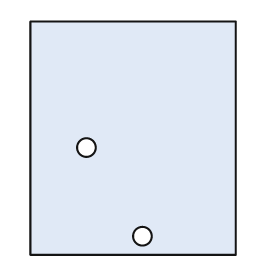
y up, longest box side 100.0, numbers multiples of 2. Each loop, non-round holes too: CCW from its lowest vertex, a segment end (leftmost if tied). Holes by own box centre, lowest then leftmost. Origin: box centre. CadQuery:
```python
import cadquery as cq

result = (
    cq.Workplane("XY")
    .moveTo(-44.0, -50.0)
    .lineTo(44.0, -50.0)
    .lineTo(44.0, 50.0)
    .lineTo(-44.0, 50.0)
    .close()
    .moveTo(4.0, -42.0)
    .circle(4.0)
    .moveTo(-20.0, -4.0)
    .circle(4.0)
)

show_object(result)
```